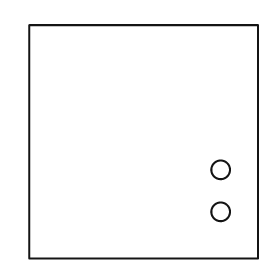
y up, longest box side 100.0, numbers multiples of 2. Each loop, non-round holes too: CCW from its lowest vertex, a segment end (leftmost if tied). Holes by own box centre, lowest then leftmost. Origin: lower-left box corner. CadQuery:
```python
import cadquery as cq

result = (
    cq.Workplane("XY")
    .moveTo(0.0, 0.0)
    .lineTo(98.0, 0.0)
    .lineTo(98.0, 100.0)
    .lineTo(0.0, 100.0)
    .close()
    .moveTo(82.0, 20.0)
    .circle(4.0)
    .moveTo(82.0, 38.0)
    .circle(4.0)
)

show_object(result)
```